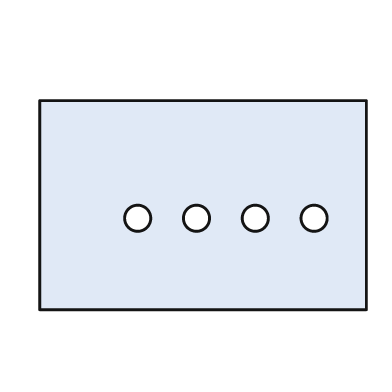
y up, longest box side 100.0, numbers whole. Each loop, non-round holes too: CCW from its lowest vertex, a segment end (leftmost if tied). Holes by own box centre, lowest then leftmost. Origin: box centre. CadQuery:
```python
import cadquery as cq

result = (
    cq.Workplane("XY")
    .moveTo(-50.0, -32.0)
    .lineTo(50.0, -32.0)
    .lineTo(50.0, 32.0)
    .lineTo(-50.0, 32.0)
    .close()
    .moveTo(-20.0, -4.0)
    .circle(4.0)
    .moveTo(-2.0, -4.0)
    .circle(4.0)
    .moveTo(16.0, -4.0)
    .circle(4.0)
    .moveTo(34.0, -4.0)
    .circle(4.0)
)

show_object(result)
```